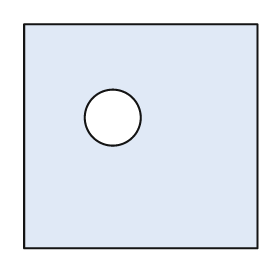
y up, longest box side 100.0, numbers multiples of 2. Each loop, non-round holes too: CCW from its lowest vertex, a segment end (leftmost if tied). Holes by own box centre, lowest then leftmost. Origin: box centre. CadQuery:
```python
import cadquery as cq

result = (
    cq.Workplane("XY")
    .moveTo(-50.0, -48.0)
    .lineTo(50.0, -48.0)
    .lineTo(50.0, 48.0)
    .lineTo(-50.0, 48.0)
    .close()
    .moveTo(-12.0, 8.0)
    .circle(12.0)
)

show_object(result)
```